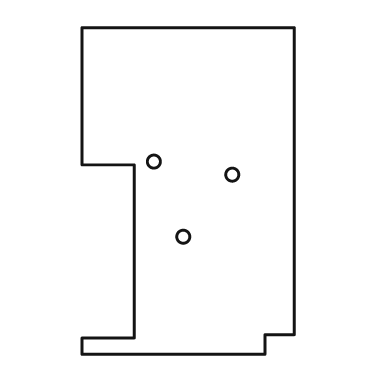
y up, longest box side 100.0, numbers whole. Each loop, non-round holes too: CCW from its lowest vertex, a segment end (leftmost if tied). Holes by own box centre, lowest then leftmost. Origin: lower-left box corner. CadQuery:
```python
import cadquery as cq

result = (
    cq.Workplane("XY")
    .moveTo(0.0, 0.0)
    .lineTo(56.0, 0.0)
    .lineTo(56.0, 6.0)
    .lineTo(65.0, 6.0)
    .lineTo(65.0, 100.0)
    .lineTo(0.0, 100.0)
    .lineTo(0.0, 58.0)
    .lineTo(16.0, 58.0)
    .lineTo(16.0, 5.0)
    .lineTo(0.0, 5.0)
    .close()
    .moveTo(31.0, 36.0)
    .circle(2.0)
    .moveTo(46.0, 55.0)
    .circle(2.0)
    .moveTo(22.0, 59.0)
    .circle(2.0)
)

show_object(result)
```